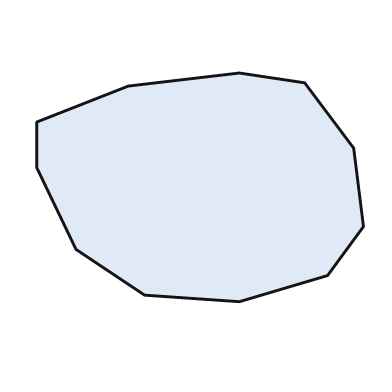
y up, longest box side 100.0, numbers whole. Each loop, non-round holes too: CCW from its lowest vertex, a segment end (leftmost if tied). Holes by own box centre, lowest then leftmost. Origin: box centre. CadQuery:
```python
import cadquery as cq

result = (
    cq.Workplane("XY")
    .moveTo(12.0, -35.0)
    .lineTo(39.0, -27.0)
    .lineTo(50.0, -12.0)
    .lineTo(47.0, 12.0)
    .lineTo(32.0, 32.0)
    .lineTo(12.0, 35.0)
    .lineTo(-22.0, 31.0)
    .lineTo(-50.0, 20.0)
    .lineTo(-50.0, 6.0)
    .lineTo(-38.0, -19.0)
    .lineTo(-17.0, -33.0)
    .close()
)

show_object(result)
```